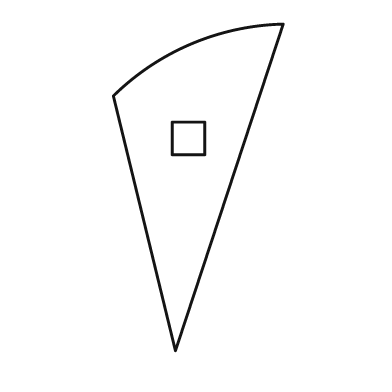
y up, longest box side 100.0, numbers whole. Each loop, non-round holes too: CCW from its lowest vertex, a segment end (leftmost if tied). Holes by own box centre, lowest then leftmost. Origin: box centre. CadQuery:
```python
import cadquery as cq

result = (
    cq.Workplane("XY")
    .moveTo(-7.0, -50.0)
    .lineTo(26.0, 50.0)
    .threePointArc((-2.0, 44.0), (-26.0, 28.0))
    .close()
    .moveTo(-8.0, 10.0)
    .lineTo(2.0, 10.0)
    .lineTo(2.0, 20.0)
    .lineTo(-8.0, 20.0)
    .close()
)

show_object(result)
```